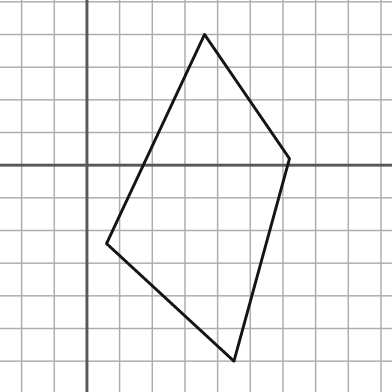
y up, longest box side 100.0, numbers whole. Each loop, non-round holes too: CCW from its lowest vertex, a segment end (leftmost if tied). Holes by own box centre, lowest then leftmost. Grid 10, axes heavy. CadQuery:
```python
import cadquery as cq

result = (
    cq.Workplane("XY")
    .moveTo(45.0, -60.0)
    .lineTo(62.0, 2.0)
    .lineTo(36.0, 40.0)
    .lineTo(6.0, -24.0)
    .close()
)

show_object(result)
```